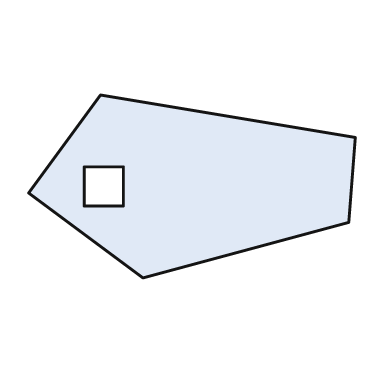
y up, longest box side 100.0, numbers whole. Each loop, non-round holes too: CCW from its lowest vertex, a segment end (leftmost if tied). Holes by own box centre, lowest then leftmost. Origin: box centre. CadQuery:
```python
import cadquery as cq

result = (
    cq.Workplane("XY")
    .moveTo(-15.0, -28.0)
    .lineTo(48.0, -11.0)
    .lineTo(50.0, 15.0)
    .lineTo(-28.0, 28.0)
    .lineTo(-50.0, -2.0)
    .close()
    .moveTo(-33.0, -6.0)
    .lineTo(-21.0, -6.0)
    .lineTo(-21.0, 6.0)
    .lineTo(-33.0, 6.0)
    .close()
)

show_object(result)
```